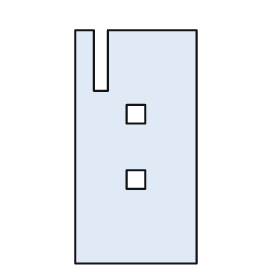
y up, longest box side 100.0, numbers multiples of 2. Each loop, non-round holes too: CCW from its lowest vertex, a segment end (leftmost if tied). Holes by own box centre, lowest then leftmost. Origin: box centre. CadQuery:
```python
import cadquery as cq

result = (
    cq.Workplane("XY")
    .moveTo(-26.0, -50.0)
    .lineTo(26.0, -50.0)
    .lineTo(26.0, 50.0)
    .lineTo(-12.0, 50.0)
    .lineTo(-12.0, 24.0)
    .lineTo(-18.0, 24.0)
    .lineTo(-18.0, 50.0)
    .lineTo(-26.0, 50.0)
    .close()
    .moveTo(-4.0, -18.0)
    .lineTo(4.0, -18.0)
    .lineTo(4.0, -10.0)
    .lineTo(-4.0, -10.0)
    .close()
    .moveTo(-4.0, 10.0)
    .lineTo(4.0, 10.0)
    .lineTo(4.0, 18.0)
    .lineTo(-4.0, 18.0)
    .close()
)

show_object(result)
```